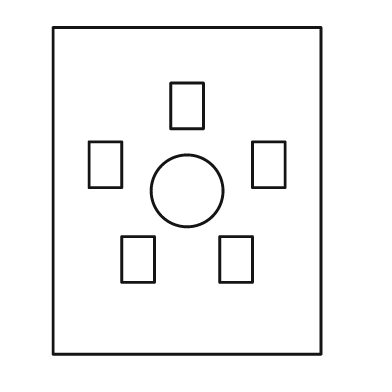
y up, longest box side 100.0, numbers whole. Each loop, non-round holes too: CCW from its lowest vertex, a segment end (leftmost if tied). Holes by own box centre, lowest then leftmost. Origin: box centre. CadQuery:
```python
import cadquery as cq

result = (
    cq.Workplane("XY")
    .moveTo(-41.0, -50.0)
    .lineTo(41.0, -50.0)
    .lineTo(41.0, 50.0)
    .lineTo(-41.0, 50.0)
    .close()
    .moveTo(-20.0, -28.0)
    .lineTo(-10.0, -28.0)
    .lineTo(-10.0, -14.0)
    .lineTo(-20.0, -14.0)
    .close()
    .moveTo(10.0, -28.0)
    .lineTo(20.0, -28.0)
    .lineTo(20.0, -14.0)
    .lineTo(10.0, -14.0)
    .close()
    .moveTo(0.0, 0.0)
    .circle(11.0)
    .moveTo(-30.0, 1.0)
    .lineTo(-20.0, 1.0)
    .lineTo(-20.0, 15.0)
    .lineTo(-30.0, 15.0)
    .close()
    .moveTo(20.0, 1.0)
    .lineTo(30.0, 1.0)
    .lineTo(30.0, 15.0)
    .lineTo(20.0, 15.0)
    .close()
    .moveTo(-5.0, 19.0)
    .lineTo(5.0, 19.0)
    .lineTo(5.0, 33.0)
    .lineTo(-5.0, 33.0)
    .close()
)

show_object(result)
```